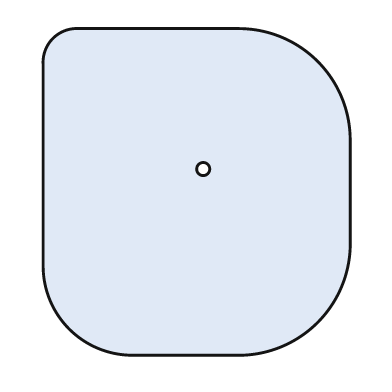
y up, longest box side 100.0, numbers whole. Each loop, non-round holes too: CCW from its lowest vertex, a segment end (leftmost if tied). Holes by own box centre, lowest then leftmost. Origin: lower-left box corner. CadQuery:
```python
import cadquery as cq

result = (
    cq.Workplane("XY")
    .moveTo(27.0, 0.0)
    .lineTo(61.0, 0.0)
    .threePointArc((84.0, 10.0), (94.0, 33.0))
    .lineTo(94.0, 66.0)
    .threePointArc((84.0, 90.0), (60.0, 100.0))
    .lineTo(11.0, 100.0)
    .threePointArc((3.0, 97.0), (0.0, 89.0))
    .lineTo(0.0, 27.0)
    .threePointArc((8.0, 8.0), (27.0, 0.0))
    .close()
    .moveTo(49.0, 57.0)
    .circle(2.0)
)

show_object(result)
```